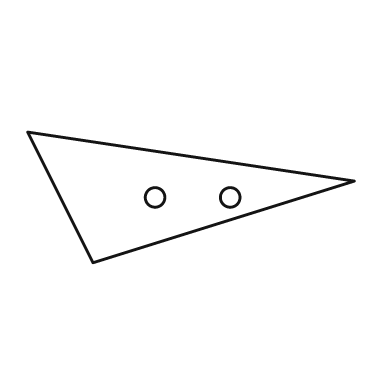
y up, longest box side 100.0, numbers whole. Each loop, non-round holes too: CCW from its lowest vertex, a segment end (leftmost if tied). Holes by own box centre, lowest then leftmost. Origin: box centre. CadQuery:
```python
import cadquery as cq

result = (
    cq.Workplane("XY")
    .moveTo(-30.0, -20.0)
    .lineTo(50.0, 5.0)
    .lineTo(-50.0, 20.0)
    .close()
    .moveTo(-11.0, 0.0)
    .circle(3.0)
    .moveTo(12.0, 0.0)
    .circle(3.0)
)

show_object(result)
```